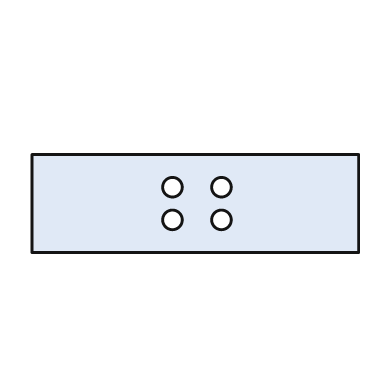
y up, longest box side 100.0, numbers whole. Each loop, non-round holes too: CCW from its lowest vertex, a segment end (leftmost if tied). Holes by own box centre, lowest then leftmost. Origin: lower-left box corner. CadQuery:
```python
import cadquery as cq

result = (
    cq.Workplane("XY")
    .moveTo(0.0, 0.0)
    .lineTo(100.0, 0.0)
    .lineTo(100.0, 30.0)
    .lineTo(0.0, 30.0)
    .close()
    .moveTo(43.0, 10.0)
    .circle(3.0)
    .moveTo(58.0, 10.0)
    .circle(3.0)
    .moveTo(43.0, 20.0)
    .circle(3.0)
    .moveTo(58.0, 20.0)
    .circle(3.0)
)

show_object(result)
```